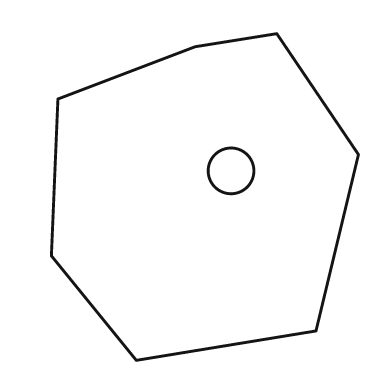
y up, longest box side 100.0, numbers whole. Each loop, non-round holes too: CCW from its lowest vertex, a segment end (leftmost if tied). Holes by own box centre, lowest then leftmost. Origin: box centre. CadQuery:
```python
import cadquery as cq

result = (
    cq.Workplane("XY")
    .moveTo(-21.0, -50.0)
    .lineTo(34.0, -41.0)
    .lineTo(47.0, 13.0)
    .lineTo(22.0, 50.0)
    .lineTo(-3.0, 46.0)
    .lineTo(-45.0, 30.0)
    .lineTo(-47.0, -18.0)
    .close()
    .moveTo(8.0, 8.0)
    .circle(7.0)
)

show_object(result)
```